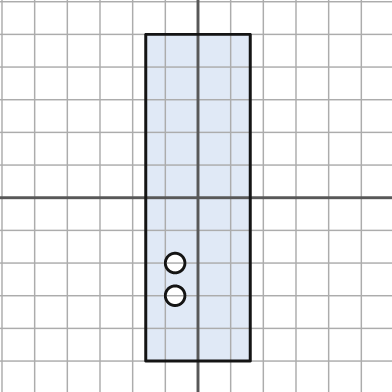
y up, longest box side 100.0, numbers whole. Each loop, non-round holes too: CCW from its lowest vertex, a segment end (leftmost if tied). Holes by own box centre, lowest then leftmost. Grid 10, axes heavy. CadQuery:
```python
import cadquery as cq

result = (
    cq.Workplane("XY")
    .moveTo(-16.0, -50.0)
    .lineTo(16.0, -50.0)
    .lineTo(16.0, 50.0)
    .lineTo(-16.0, 50.0)
    .close()
    .moveTo(-7.0, -30.0)
    .circle(3.0)
    .moveTo(-7.0, -20.0)
    .circle(3.0)
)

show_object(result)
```